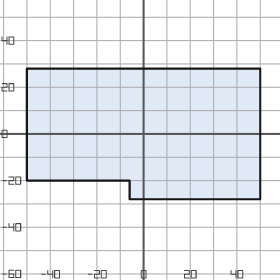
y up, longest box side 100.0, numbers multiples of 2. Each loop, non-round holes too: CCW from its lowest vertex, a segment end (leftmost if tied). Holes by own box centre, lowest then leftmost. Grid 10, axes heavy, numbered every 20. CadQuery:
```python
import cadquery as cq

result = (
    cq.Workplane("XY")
    .moveTo(-6.0, -28.0)
    .lineTo(50.0, -28.0)
    .lineTo(50.0, 28.0)
    .lineTo(-50.0, 28.0)
    .lineTo(-50.0, -20.0)
    .lineTo(-6.0, -20.0)
    .close()
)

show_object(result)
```